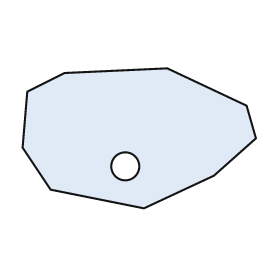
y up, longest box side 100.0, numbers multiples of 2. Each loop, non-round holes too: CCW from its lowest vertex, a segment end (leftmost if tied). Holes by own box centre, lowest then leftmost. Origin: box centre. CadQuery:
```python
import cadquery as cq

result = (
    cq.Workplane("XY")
    .moveTo(2.0, -30.0)
    .lineTo(32.0, -16.0)
    .lineTo(50.0, 0.0)
    .lineTo(46.0, 14.0)
    .lineTo(12.0, 30.0)
    .lineTo(-32.0, 28.0)
    .lineTo(-48.0, 20.0)
    .lineTo(-50.0, -4.0)
    .lineTo(-38.0, -22.0)
    .close()
    .moveTo(-6.0, -12.0)
    .circle(6.0)
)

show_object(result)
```